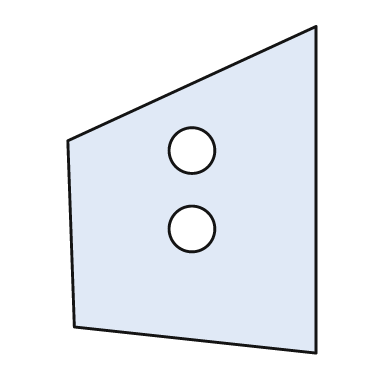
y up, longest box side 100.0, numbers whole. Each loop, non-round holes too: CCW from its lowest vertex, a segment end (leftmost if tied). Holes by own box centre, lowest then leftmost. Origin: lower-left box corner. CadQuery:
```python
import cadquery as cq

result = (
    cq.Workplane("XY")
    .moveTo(76.0, 0.0)
    .lineTo(76.0, 100.0)
    .lineTo(0.0, 65.0)
    .lineTo(2.0, 8.0)
    .close()
    .moveTo(38.0, 38.0)
    .circle(7.0)
    .moveTo(38.0, 62.0)
    .circle(7.0)
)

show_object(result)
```